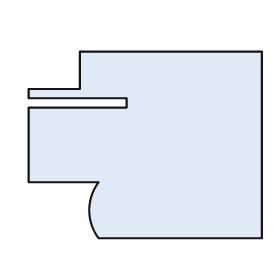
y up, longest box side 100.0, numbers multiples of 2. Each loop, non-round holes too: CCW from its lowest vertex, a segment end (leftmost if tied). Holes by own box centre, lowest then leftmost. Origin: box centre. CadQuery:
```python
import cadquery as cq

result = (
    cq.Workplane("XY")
    .moveTo(-20.0, -40.0)
    .lineTo(50.0, -40.0)
    .lineTo(50.0, 40.0)
    .lineTo(-28.0, 40.0)
    .lineTo(-28.0, 24.0)
    .lineTo(-50.0, 24.0)
    .lineTo(-50.0, 20.0)
    .lineTo(-8.0, 20.0)
    .lineTo(-8.0, 16.0)
    .lineTo(-50.0, 16.0)
    .lineTo(-50.0, -16.0)
    .lineTo(-20.0, -16.0)
    .threePointArc((-24.0, -28.0), (-20.0, -40.0))
    .close()
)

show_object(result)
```